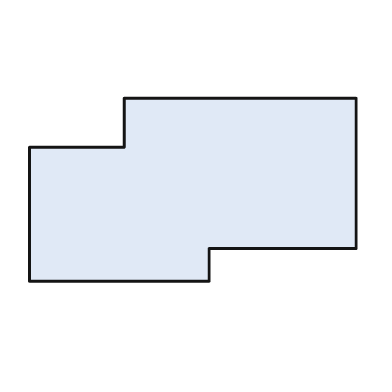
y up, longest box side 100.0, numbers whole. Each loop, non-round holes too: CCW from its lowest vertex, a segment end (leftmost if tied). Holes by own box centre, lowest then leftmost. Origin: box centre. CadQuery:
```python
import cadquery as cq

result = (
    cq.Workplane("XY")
    .moveTo(-50.0, -28.0)
    .lineTo(5.0, -28.0)
    .lineTo(5.0, -18.0)
    .lineTo(50.0, -18.0)
    .lineTo(50.0, 28.0)
    .lineTo(-21.0, 28.0)
    .lineTo(-21.0, 13.0)
    .lineTo(-50.0, 13.0)
    .close()
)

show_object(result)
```